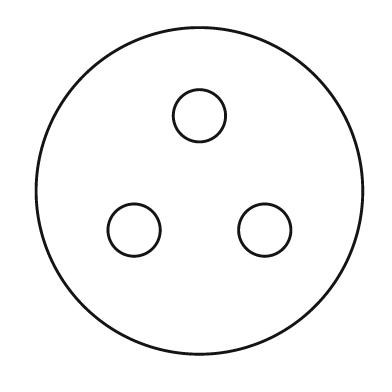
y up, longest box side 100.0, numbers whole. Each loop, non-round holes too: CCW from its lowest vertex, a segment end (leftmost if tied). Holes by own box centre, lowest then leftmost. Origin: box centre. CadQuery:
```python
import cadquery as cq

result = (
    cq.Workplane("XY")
    .moveTo(0.0, 0.0)
    .circle(50.0)
    .moveTo(-20.0, -12.0)
    .circle(8.0)
    .moveTo(20.0, -12.0)
    .circle(8.0)
    .moveTo(0.0, 23.0)
    .circle(8.0)
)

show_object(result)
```